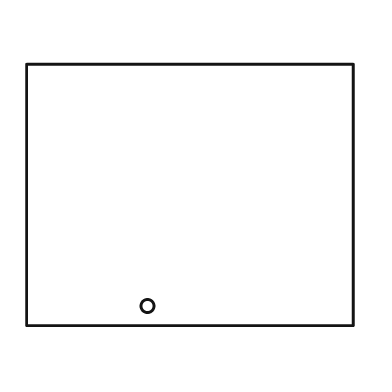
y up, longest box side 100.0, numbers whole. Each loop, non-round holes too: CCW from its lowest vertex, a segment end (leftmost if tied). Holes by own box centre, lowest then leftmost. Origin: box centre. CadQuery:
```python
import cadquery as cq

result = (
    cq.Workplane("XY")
    .moveTo(-50.0, -40.0)
    .lineTo(50.0, -40.0)
    .lineTo(50.0, 40.0)
    .lineTo(-50.0, 40.0)
    .close()
    .moveTo(-13.0, -34.0)
    .circle(2.0)
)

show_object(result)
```